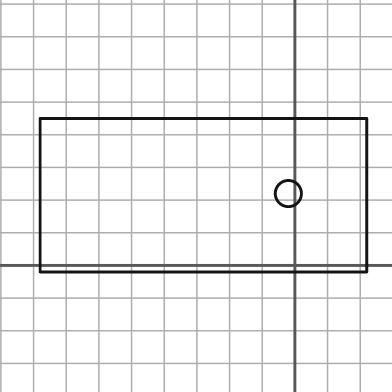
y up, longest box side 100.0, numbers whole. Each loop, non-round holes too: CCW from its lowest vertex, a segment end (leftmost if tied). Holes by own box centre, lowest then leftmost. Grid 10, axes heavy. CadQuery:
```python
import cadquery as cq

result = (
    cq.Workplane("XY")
    .moveTo(-78.0, -2.0)
    .lineTo(22.0, -2.0)
    .lineTo(22.0, 45.0)
    .lineTo(-78.0, 45.0)
    .close()
    .moveTo(-2.0, 22.0)
    .circle(4.0)
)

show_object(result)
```